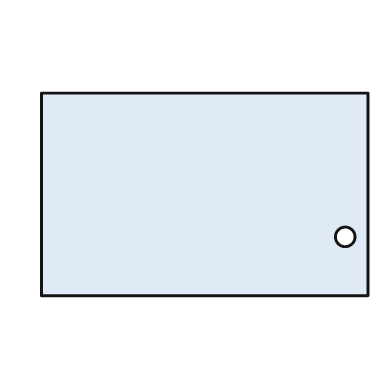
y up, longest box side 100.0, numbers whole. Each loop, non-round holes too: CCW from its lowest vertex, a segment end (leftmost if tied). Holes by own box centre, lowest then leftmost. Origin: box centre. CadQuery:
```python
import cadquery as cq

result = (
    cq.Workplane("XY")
    .moveTo(-50.0, -31.0)
    .lineTo(50.0, -31.0)
    .lineTo(50.0, 31.0)
    .lineTo(-50.0, 31.0)
    .close()
    .moveTo(43.0, -13.0)
    .circle(3.0)
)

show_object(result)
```